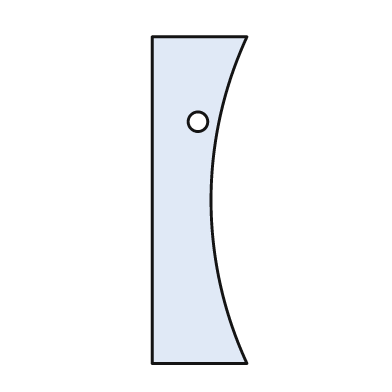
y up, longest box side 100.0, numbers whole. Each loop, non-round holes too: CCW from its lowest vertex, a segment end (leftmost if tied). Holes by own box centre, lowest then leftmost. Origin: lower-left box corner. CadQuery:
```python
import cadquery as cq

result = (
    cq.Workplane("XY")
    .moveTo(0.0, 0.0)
    .lineTo(29.0, 0.0)
    .threePointArc((18.0, 50.0), (29.0, 100.0))
    .lineTo(0.0, 100.0)
    .close()
    .moveTo(14.0, 74.0)
    .circle(3.0)
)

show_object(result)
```